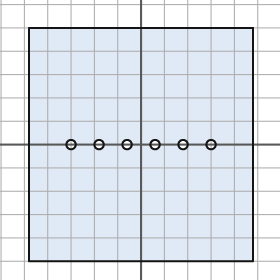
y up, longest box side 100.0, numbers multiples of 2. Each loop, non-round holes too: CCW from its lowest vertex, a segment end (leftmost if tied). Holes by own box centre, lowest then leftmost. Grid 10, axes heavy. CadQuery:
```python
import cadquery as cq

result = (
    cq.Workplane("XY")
    .moveTo(-48.0, -50.0)
    .lineTo(48.0, -50.0)
    .lineTo(48.0, 50.0)
    .lineTo(-48.0, 50.0)
    .close()
    .moveTo(-30.0, 0.0)
    .circle(2.0)
    .moveTo(-18.0, 0.0)
    .circle(2.0)
    .moveTo(-6.0, 0.0)
    .circle(2.0)
    .moveTo(6.0, 0.0)
    .circle(2.0)
    .moveTo(18.0, 0.0)
    .circle(2.0)
    .moveTo(30.0, 0.0)
    .circle(2.0)
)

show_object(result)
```